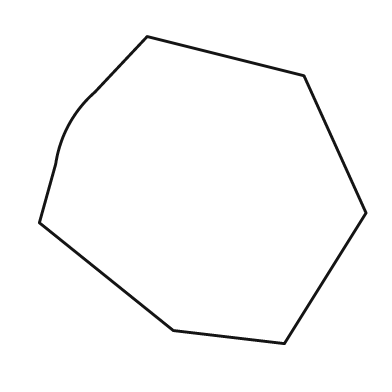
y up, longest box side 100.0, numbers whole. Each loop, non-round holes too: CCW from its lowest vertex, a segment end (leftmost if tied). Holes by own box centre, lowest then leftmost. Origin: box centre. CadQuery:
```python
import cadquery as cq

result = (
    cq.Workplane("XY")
    .moveTo(25.0, -47.0)
    .lineTo(50.0, -7.0)
    .lineTo(31.0, 35.0)
    .lineTo(-17.0, 47.0)
    .lineTo(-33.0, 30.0)
    .threePointArc((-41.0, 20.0), (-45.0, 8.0))
    .lineTo(-50.0, -10.0)
    .lineTo(-9.0, -43.0)
    .close()
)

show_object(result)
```